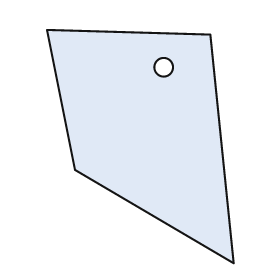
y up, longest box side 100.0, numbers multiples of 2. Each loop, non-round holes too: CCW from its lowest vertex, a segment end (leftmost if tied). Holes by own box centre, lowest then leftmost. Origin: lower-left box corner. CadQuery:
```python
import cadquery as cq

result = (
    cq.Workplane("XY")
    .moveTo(80.0, 0.0)
    .lineTo(70.0, 98.0)
    .lineTo(0.0, 100.0)
    .lineTo(12.0, 40.0)
    .close()
    .moveTo(50.0, 84.0)
    .circle(4.0)
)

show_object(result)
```